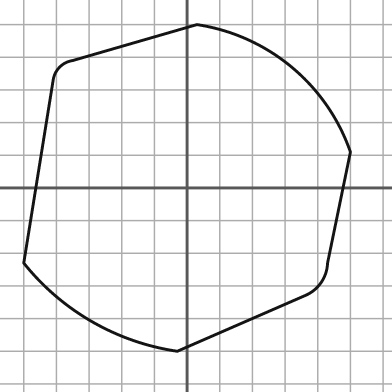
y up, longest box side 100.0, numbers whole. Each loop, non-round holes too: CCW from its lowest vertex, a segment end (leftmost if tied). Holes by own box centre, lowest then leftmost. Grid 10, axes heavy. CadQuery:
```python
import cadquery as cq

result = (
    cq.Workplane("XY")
    .moveTo(-3.0, -50.0)
    .lineTo(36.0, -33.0)
    .threePointArc((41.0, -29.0), (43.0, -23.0))
    .lineTo(50.0, 11.0)
    .threePointArc((32.0, 37.0), (3.0, 50.0))
    .lineTo(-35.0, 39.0)
    .threePointArc((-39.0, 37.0), (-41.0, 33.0))
    .lineTo(-50.0, -23.0)
    .threePointArc((-29.0, -41.0), (-3.0, -50.0))
    .close()
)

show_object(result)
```